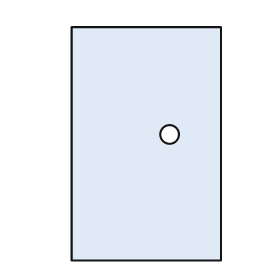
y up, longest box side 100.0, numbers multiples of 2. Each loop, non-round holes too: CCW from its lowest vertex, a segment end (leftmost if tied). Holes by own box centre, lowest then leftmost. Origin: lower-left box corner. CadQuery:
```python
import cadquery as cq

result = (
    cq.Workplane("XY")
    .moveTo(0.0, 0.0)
    .lineTo(64.0, 0.0)
    .lineTo(64.0, 100.0)
    .lineTo(0.0, 100.0)
    .close()
    .moveTo(42.0, 54.0)
    .circle(4.0)
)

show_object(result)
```